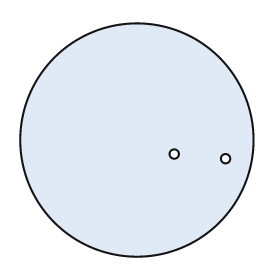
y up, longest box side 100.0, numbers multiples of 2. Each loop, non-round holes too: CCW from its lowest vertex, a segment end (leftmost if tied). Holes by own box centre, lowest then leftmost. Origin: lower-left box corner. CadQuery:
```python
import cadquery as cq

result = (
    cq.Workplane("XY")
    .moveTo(50.0, 50.0)
    .circle(50.0)
    .moveTo(88.0, 42.0)
    .circle(2.0)
    .moveTo(66.0, 44.0)
    .circle(2.0)
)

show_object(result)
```